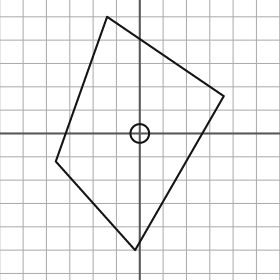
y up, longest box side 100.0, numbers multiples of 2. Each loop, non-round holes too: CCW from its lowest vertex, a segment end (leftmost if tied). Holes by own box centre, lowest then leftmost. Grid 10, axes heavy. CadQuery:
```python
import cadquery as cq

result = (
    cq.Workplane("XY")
    .moveTo(-2.0, -50.0)
    .lineTo(36.0, 16.0)
    .lineTo(-14.0, 50.0)
    .lineTo(-36.0, -12.0)
    .close()
    .moveTo(0.0, 0.0)
    .circle(4.0)
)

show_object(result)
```